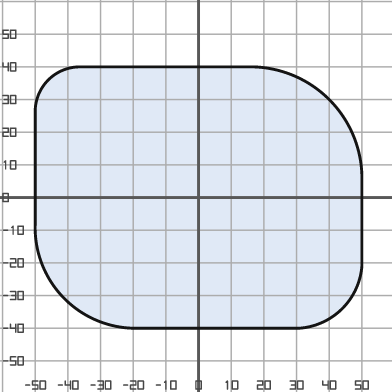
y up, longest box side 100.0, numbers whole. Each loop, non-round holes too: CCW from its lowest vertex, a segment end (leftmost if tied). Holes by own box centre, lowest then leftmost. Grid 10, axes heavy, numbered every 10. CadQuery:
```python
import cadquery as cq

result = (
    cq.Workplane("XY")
    .moveTo(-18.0, -40.0)
    .lineTo(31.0, -40.0)
    .threePointArc((44.0, -34.0), (50.0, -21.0))
    .lineTo(50.0, 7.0)
    .threePointArc((40.0, 30.0), (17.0, 40.0))
    .lineTo(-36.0, 40.0)
    .threePointArc((-46.0, 36.0), (-50.0, 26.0))
    .lineTo(-50.0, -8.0)
    .threePointArc((-41.0, -31.0), (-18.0, -40.0))
    .close()
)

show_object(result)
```